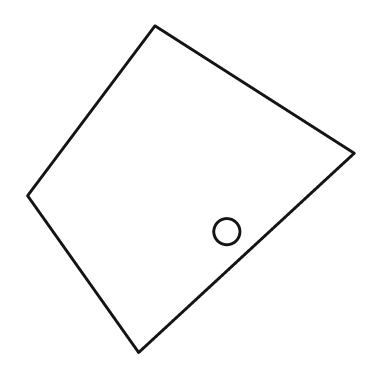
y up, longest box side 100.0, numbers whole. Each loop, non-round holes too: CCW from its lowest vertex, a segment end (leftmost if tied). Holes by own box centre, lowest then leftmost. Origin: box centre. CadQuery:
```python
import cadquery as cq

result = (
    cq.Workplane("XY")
    .moveTo(-16.0, -50.0)
    .lineTo(50.0, 11.0)
    .lineTo(-11.0, 50.0)
    .lineTo(-50.0, -2.0)
    .close()
    .moveTo(11.0, -13.0)
    .circle(4.0)
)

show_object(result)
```